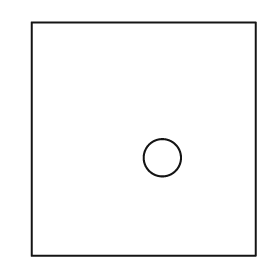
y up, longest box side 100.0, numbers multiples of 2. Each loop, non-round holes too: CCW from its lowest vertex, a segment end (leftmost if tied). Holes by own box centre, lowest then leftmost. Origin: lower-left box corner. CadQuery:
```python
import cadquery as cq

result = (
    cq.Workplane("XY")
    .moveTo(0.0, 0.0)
    .lineTo(96.0, 0.0)
    .lineTo(96.0, 100.0)
    .lineTo(0.0, 100.0)
    .close()
    .moveTo(56.0, 42.0)
    .circle(8.0)
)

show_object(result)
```